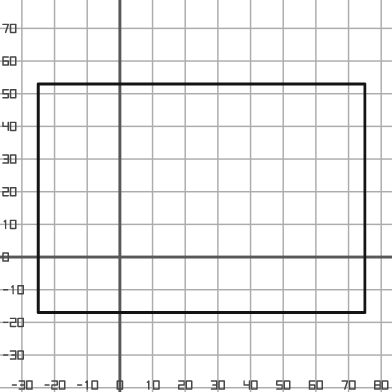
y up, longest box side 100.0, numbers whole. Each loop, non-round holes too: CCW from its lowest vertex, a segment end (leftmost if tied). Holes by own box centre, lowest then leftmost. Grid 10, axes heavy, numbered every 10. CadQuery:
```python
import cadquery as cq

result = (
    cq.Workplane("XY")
    .moveTo(-25.0, -17.0)
    .lineTo(75.0, -17.0)
    .lineTo(75.0, 53.0)
    .lineTo(-25.0, 53.0)
    .close()
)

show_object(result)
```